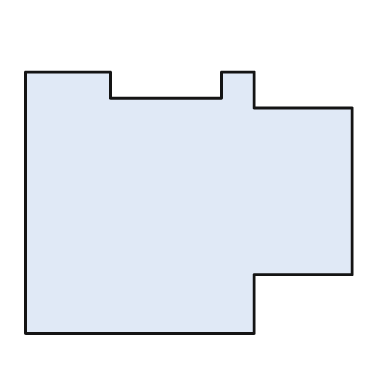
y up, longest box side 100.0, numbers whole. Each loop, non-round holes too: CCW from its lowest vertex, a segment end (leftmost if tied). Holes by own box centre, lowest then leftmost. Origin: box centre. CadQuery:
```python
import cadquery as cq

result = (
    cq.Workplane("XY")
    .moveTo(-50.0, -40.0)
    .lineTo(20.0, -40.0)
    .lineTo(20.0, -22.0)
    .lineTo(50.0, -22.0)
    .lineTo(50.0, 29.0)
    .lineTo(20.0, 29.0)
    .lineTo(20.0, 40.0)
    .lineTo(10.0, 40.0)
    .lineTo(10.0, 32.0)
    .lineTo(-24.0, 32.0)
    .lineTo(-24.0, 40.0)
    .lineTo(-50.0, 40.0)
    .close()
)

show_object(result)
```